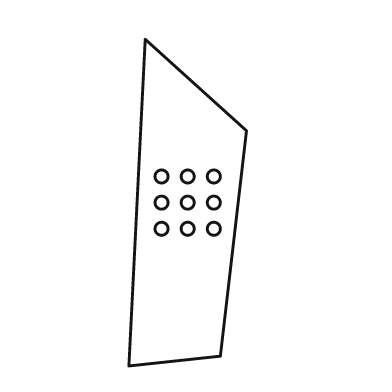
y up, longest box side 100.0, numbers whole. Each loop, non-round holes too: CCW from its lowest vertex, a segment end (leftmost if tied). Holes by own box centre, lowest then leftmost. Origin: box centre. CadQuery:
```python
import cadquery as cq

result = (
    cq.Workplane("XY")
    .moveTo(-18.0, -50.0)
    .lineTo(10.0, -47.0)
    .lineTo(18.0, 22.0)
    .lineTo(-13.0, 50.0)
    .close()
    .moveTo(-8.0, -8.0)
    .circle(2.0)
    .moveTo(0.0, -8.0)
    .circle(2.0)
    .moveTo(8.0, -8.0)
    .circle(2.0)
    .moveTo(-8.0, 0.0)
    .circle(2.0)
    .moveTo(0.0, 0.0)
    .circle(2.0)
    .moveTo(8.0, 0.0)
    .circle(2.0)
    .moveTo(-8.0, 8.0)
    .circle(2.0)
    .moveTo(0.0, 8.0)
    .circle(2.0)
    .moveTo(8.0, 8.0)
    .circle(2.0)
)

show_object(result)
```